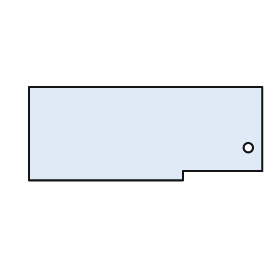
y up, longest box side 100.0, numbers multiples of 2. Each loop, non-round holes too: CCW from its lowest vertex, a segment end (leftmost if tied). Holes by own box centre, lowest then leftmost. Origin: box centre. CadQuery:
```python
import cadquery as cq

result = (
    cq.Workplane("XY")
    .moveTo(-50.0, -20.0)
    .lineTo(16.0, -20.0)
    .lineTo(16.0, -16.0)
    .lineTo(50.0, -16.0)
    .lineTo(50.0, 20.0)
    .lineTo(-50.0, 20.0)
    .close()
    .moveTo(44.0, -6.0)
    .circle(2.0)
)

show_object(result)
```